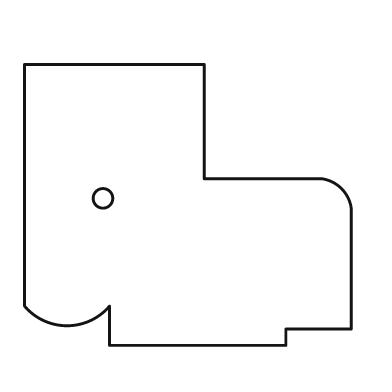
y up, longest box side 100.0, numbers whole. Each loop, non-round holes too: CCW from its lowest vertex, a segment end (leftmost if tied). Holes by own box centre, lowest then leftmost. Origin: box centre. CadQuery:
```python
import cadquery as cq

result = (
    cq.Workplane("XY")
    .moveTo(-24.0, -43.0)
    .lineTo(30.0, -43.0)
    .lineTo(30.0, -38.0)
    .lineTo(50.0, -38.0)
    .lineTo(50.0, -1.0)
    .threePointArc((47.0, 5.0), (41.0, 8.0))
    .lineTo(5.0, 8.0)
    .lineTo(5.0, 43.0)
    .lineTo(-50.0, 43.0)
    .lineTo(-50.0, -31.0)
    .threePointArc((-37.0, -37.0), (-24.0, -31.0))
    .close()
    .moveTo(-26.0, 2.0)
    .circle(3.0)
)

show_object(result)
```